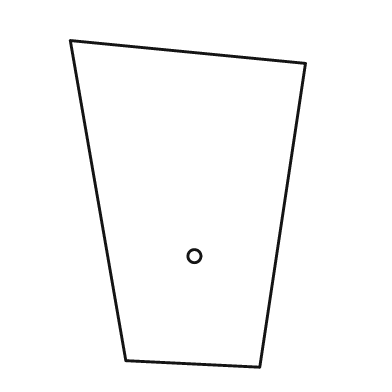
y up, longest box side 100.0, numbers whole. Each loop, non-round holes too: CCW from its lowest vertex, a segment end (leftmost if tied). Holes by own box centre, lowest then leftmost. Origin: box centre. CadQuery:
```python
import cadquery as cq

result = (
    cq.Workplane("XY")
    .moveTo(22.0, -50.0)
    .lineTo(36.0, 43.0)
    .lineTo(-36.0, 50.0)
    .lineTo(-19.0, -48.0)
    .close()
    .moveTo(2.0, -16.0)
    .circle(2.0)
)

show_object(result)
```